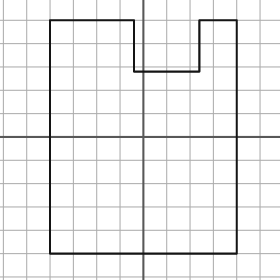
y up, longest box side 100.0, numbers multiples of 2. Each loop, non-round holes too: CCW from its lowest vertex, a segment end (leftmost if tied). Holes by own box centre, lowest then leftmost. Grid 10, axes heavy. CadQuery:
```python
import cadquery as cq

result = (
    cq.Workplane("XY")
    .moveTo(-40.0, -50.0)
    .lineTo(40.0, -50.0)
    .lineTo(40.0, 50.0)
    .lineTo(24.0, 50.0)
    .lineTo(24.0, 28.0)
    .lineTo(-4.0, 28.0)
    .lineTo(-4.0, 50.0)
    .lineTo(-40.0, 50.0)
    .close()
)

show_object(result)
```